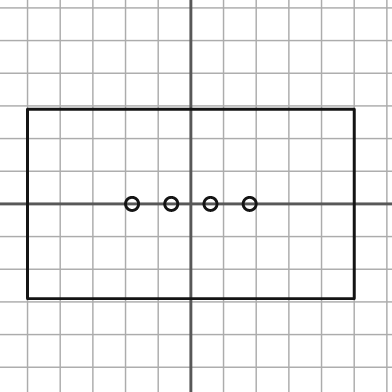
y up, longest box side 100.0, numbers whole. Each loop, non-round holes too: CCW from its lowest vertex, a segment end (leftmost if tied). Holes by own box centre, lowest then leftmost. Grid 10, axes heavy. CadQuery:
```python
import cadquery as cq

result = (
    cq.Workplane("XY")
    .moveTo(-50.0, -29.0)
    .lineTo(50.0, -29.0)
    .lineTo(50.0, 29.0)
    .lineTo(-50.0, 29.0)
    .close()
    .moveTo(-18.0, 0.0)
    .circle(2.0)
    .moveTo(-6.0, 0.0)
    .circle(2.0)
    .moveTo(6.0, 0.0)
    .circle(2.0)
    .moveTo(18.0, 0.0)
    .circle(2.0)
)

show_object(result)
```